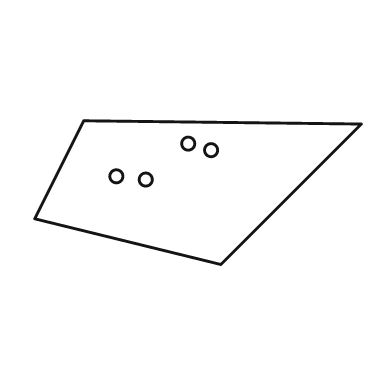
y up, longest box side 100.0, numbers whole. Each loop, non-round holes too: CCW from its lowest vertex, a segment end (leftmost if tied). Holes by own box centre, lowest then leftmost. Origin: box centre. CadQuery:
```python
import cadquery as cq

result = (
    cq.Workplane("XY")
    .moveTo(7.0, -22.0)
    .lineTo(50.0, 21.0)
    .lineTo(-35.0, 22.0)
    .lineTo(-50.0, -8.0)
    .close()
    .moveTo(-16.0, 4.0)
    .circle(2.0)
    .moveTo(-25.0, 5.0)
    .circle(2.0)
    .moveTo(4.0, 13.0)
    .circle(2.0)
    .moveTo(-3.0, 15.0)
    .circle(2.0)
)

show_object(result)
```